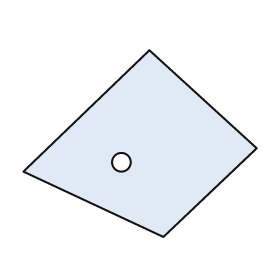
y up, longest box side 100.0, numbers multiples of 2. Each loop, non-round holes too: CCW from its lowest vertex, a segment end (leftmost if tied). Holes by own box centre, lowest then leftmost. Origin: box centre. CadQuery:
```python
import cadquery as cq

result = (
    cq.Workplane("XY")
    .moveTo(10.0, -40.0)
    .lineTo(50.0, -2.0)
    .lineTo(4.0, 40.0)
    .lineTo(-50.0, -12.0)
    .close()
    .moveTo(-8.0, -8.0)
    .circle(4.0)
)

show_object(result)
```